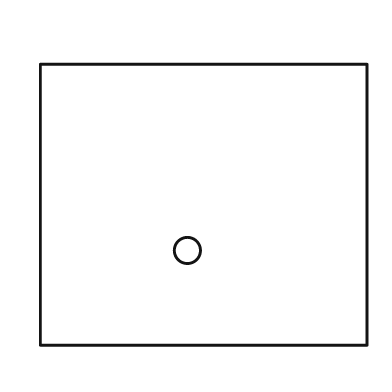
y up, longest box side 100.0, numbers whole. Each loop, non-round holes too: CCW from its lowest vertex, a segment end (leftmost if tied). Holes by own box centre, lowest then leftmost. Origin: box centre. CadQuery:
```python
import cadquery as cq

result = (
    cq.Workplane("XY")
    .moveTo(-50.0, -43.0)
    .lineTo(50.0, -43.0)
    .lineTo(50.0, 43.0)
    .lineTo(-50.0, 43.0)
    .close()
    .moveTo(-5.0, -14.0)
    .circle(4.0)
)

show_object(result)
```